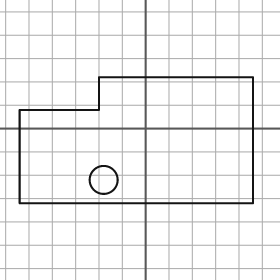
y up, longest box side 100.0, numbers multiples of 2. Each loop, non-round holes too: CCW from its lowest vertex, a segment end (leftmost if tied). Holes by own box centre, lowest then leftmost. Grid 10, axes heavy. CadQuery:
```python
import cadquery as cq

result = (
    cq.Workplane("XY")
    .moveTo(-54.0, -32.0)
    .lineTo(46.0, -32.0)
    .lineTo(46.0, 22.0)
    .lineTo(-20.0, 22.0)
    .lineTo(-20.0, 8.0)
    .lineTo(-54.0, 8.0)
    .close()
    .moveTo(-18.0, -22.0)
    .circle(6.0)
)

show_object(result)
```